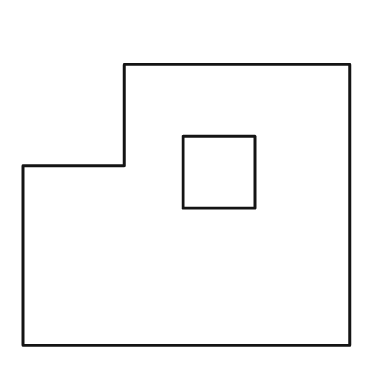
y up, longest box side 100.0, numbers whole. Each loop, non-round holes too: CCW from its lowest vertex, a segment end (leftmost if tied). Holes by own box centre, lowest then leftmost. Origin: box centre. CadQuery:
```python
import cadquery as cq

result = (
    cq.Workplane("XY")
    .moveTo(-50.0, -43.0)
    .lineTo(50.0, -43.0)
    .lineTo(50.0, 43.0)
    .lineTo(-19.0, 43.0)
    .lineTo(-19.0, 12.0)
    .lineTo(-50.0, 12.0)
    .close()
    .moveTo(-1.0, -1.0)
    .lineTo(21.0, -1.0)
    .lineTo(21.0, 21.0)
    .lineTo(-1.0, 21.0)
    .close()
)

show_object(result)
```